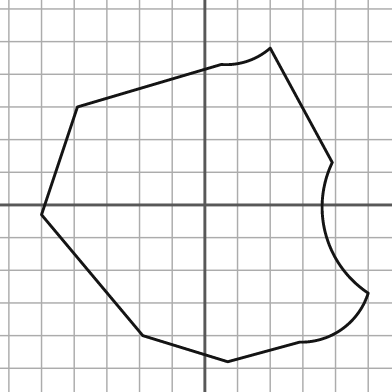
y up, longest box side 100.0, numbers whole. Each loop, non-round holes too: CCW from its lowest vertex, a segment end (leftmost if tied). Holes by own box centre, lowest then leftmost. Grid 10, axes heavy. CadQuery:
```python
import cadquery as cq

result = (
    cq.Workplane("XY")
    .moveTo(7.0, -48.0)
    .lineTo(29.0, -42.0)
    .threePointArc((42.0, -38.0), (50.0, -27.0))
    .threePointArc((37.0, -9.0), (39.0, 13.0))
    .lineTo(20.0, 48.0)
    .threePointArc((13.0, 44.0), (5.0, 43.0))
    .lineTo(-39.0, 30.0)
    .lineTo(-50.0, -3.0)
    .lineTo(-19.0, -40.0)
    .close()
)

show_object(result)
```